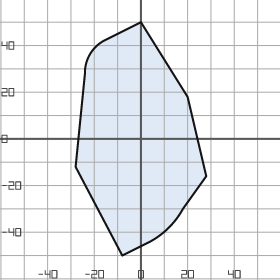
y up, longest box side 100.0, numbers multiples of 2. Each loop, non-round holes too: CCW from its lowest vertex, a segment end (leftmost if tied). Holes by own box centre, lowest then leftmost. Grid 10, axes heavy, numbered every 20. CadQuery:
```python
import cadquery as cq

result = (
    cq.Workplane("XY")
    .moveTo(-8.0, -50.0)
    .lineTo(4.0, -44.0)
    .threePointArc((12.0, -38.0), (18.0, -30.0))
    .lineTo(28.0, -16.0)
    .lineTo(20.0, 18.0)
    .lineTo(0.0, 50.0)
    .lineTo(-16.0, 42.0)
    .threePointArc((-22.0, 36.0), (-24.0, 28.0))
    .lineTo(-28.0, -12.0)
    .close()
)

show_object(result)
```